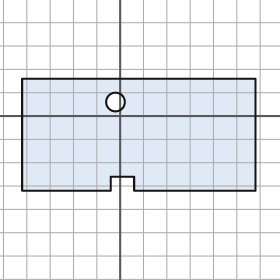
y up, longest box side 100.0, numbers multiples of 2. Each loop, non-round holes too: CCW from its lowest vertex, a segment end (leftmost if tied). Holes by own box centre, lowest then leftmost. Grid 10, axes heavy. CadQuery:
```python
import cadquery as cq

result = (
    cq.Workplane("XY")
    .moveTo(-42.0, -32.0)
    .lineTo(-4.0, -32.0)
    .lineTo(-4.0, -26.0)
    .lineTo(6.0, -26.0)
    .lineTo(6.0, -32.0)
    .lineTo(58.0, -32.0)
    .lineTo(58.0, 16.0)
    .lineTo(-42.0, 16.0)
    .close()
    .moveTo(-2.0, 6.0)
    .circle(4.0)
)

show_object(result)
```